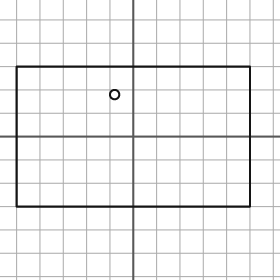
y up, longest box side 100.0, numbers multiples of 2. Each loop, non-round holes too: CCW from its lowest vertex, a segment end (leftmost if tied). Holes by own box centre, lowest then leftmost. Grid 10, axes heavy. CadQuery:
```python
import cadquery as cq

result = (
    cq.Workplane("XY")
    .moveTo(-50.0, -30.0)
    .lineTo(50.0, -30.0)
    .lineTo(50.0, 30.0)
    .lineTo(-50.0, 30.0)
    .close()
    .moveTo(-8.0, 18.0)
    .circle(2.0)
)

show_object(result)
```